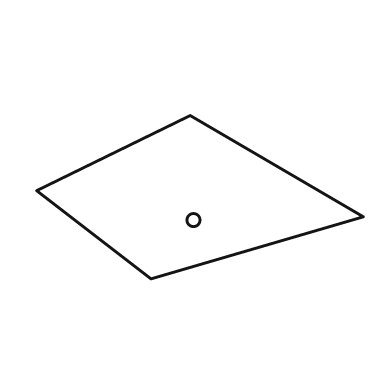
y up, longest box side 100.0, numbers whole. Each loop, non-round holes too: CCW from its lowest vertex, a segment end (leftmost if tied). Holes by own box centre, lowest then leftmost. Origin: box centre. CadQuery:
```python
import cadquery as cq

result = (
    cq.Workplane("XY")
    .moveTo(-15.0, -25.0)
    .lineTo(50.0, -6.0)
    .lineTo(-3.0, 25.0)
    .lineTo(-50.0, 2.0)
    .close()
    .moveTo(-2.0, -7.0)
    .circle(2.0)
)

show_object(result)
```